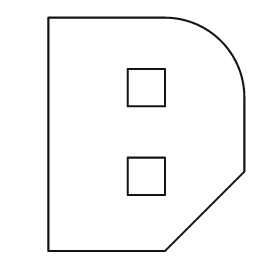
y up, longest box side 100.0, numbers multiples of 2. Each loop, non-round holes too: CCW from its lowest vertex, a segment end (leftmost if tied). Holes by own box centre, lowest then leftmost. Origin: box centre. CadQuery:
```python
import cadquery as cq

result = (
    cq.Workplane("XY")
    .moveTo(-42.0, -50.0)
    .lineTo(8.0, -50.0)
    .lineTo(42.0, -16.0)
    .lineTo(42.0, 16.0)
    .threePointArc((32.0, 40.0), (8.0, 50.0))
    .lineTo(-42.0, 50.0)
    .close()
    .moveTo(-8.0, -26.0)
    .lineTo(8.0, -26.0)
    .lineTo(8.0, -10.0)
    .lineTo(-8.0, -10.0)
    .close()
    .moveTo(-8.0, 12.0)
    .lineTo(8.0, 12.0)
    .lineTo(8.0, 28.0)
    .lineTo(-8.0, 28.0)
    .close()
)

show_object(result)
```